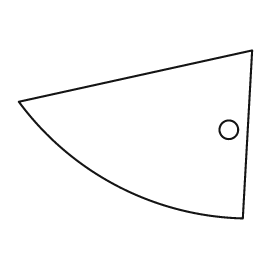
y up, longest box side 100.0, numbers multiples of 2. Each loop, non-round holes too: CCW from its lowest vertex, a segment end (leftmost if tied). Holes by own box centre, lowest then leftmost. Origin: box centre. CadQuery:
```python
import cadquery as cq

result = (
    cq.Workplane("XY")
    .moveTo(46.0, -36.0)
    .lineTo(50.0, 36.0)
    .lineTo(-50.0, 14.0)
    .threePointArc((-8.0, -22.0), (46.0, -36.0))
    .close()
    .moveTo(40.0, 2.0)
    .circle(4.0)
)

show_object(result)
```